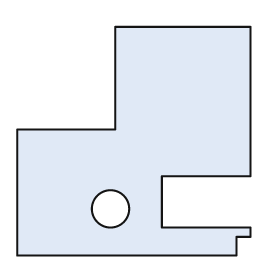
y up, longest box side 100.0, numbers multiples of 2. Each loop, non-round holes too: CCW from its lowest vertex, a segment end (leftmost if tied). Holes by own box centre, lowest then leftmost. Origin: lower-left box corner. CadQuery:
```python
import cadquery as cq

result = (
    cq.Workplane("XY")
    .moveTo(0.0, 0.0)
    .lineTo(94.0, 0.0)
    .lineTo(94.0, 8.0)
    .lineTo(100.0, 8.0)
    .lineTo(100.0, 12.0)
    .lineTo(62.0, 12.0)
    .lineTo(62.0, 34.0)
    .lineTo(100.0, 34.0)
    .lineTo(100.0, 98.0)
    .lineTo(42.0, 98.0)
    .lineTo(42.0, 54.0)
    .lineTo(0.0, 54.0)
    .close()
    .moveTo(40.0, 20.0)
    .circle(8.0)
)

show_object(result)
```